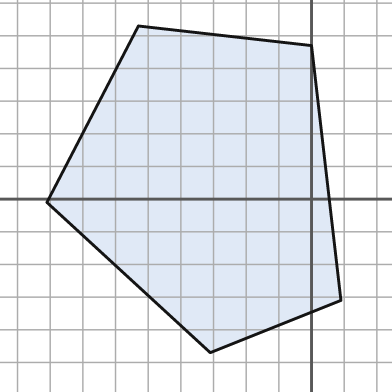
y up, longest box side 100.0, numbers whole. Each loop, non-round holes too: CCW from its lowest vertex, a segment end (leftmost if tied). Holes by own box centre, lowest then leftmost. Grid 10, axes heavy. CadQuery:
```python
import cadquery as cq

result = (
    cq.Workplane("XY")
    .moveTo(-31.0, -47.0)
    .lineTo(9.0, -31.0)
    .lineTo(0.0, 47.0)
    .lineTo(-53.0, 53.0)
    .lineTo(-81.0, -1.0)
    .close()
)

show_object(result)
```